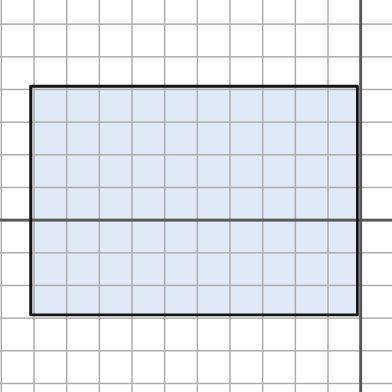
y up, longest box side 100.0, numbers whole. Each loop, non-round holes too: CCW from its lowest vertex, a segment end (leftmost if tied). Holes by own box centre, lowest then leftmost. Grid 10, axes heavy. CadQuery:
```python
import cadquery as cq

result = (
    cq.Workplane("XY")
    .moveTo(-101.0, -29.0)
    .lineTo(-1.0, -29.0)
    .lineTo(-1.0, 41.0)
    .lineTo(-101.0, 41.0)
    .close()
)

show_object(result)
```